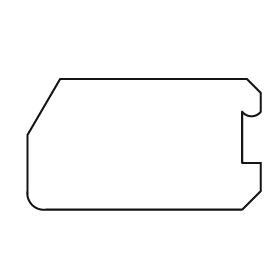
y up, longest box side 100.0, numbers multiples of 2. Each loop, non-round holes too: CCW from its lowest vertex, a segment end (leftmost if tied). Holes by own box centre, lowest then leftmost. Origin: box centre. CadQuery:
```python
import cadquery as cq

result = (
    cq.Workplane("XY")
    .moveTo(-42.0, -28.0)
    .lineTo(42.0, -28.0)
    .lineTo(50.0, -20.0)
    .lineTo(50.0, -8.0)
    .lineTo(42.0, -8.0)
    .lineTo(42.0, 14.0)
    .threePointArc((46.0, 12.0), (50.0, 14.0))
    .lineTo(50.0, 22.0)
    .lineTo(44.0, 28.0)
    .lineTo(-36.0, 28.0)
    .lineTo(-50.0, 4.0)
    .lineTo(-50.0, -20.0)
    .threePointArc((-48.0, -26.0), (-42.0, -28.0))
    .close()
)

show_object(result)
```